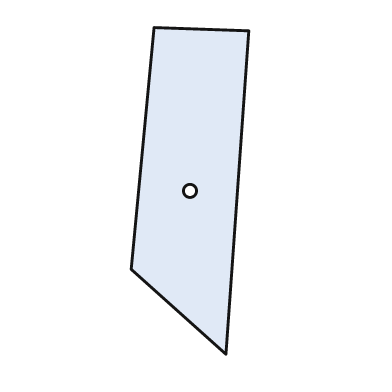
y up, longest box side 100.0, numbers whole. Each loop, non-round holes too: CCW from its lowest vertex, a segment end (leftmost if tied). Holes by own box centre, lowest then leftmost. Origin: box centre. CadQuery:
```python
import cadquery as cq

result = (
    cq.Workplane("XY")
    .moveTo(11.0, -50.0)
    .lineTo(18.0, 49.0)
    .lineTo(-11.0, 50.0)
    .lineTo(-18.0, -24.0)
    .close()
    .moveTo(0.0, 0.0)
    .circle(2.0)
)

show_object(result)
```